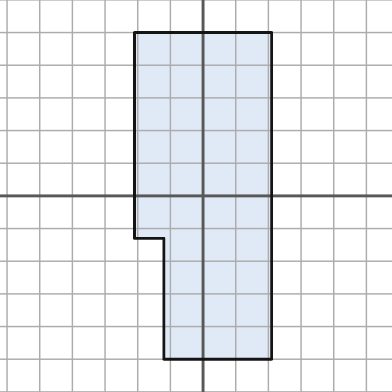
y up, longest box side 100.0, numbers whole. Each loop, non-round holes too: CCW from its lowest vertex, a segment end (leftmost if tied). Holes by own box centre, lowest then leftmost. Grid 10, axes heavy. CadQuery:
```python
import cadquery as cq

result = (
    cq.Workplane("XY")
    .moveTo(-12.0, -50.0)
    .lineTo(21.0, -50.0)
    .lineTo(21.0, 50.0)
    .lineTo(-21.0, 50.0)
    .lineTo(-21.0, -13.0)
    .lineTo(-12.0, -13.0)
    .close()
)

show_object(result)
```